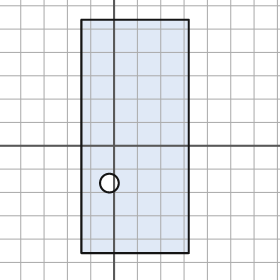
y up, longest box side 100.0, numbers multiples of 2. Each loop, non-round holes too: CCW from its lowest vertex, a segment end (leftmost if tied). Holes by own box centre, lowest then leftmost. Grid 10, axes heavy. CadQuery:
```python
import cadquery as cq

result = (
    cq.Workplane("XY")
    .moveTo(-14.0, -46.0)
    .lineTo(32.0, -46.0)
    .lineTo(32.0, 54.0)
    .lineTo(-14.0, 54.0)
    .close()
    .moveTo(-2.0, -16.0)
    .circle(4.0)
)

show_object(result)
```